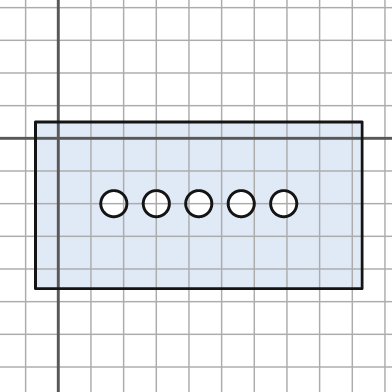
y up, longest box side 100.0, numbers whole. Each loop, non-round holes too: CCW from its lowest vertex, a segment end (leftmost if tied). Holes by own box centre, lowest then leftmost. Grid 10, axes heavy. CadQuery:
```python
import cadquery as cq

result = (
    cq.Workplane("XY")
    .moveTo(-7.0, -46.0)
    .lineTo(93.0, -46.0)
    .lineTo(93.0, 5.0)
    .lineTo(-7.0, 5.0)
    .close()
    .moveTo(17.0, -20.0)
    .circle(4.0)
    .moveTo(30.0, -20.0)
    .circle(4.0)
    .moveTo(43.0, -20.0)
    .circle(4.0)
    .moveTo(56.0, -20.0)
    .circle(4.0)
    .moveTo(69.0, -20.0)
    .circle(4.0)
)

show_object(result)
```